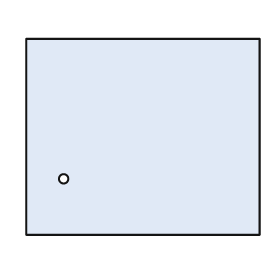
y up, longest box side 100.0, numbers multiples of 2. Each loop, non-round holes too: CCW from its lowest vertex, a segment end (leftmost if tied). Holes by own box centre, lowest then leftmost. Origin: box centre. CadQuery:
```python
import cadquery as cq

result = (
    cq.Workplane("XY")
    .moveTo(-50.0, -42.0)
    .lineTo(50.0, -42.0)
    .lineTo(50.0, 42.0)
    .lineTo(-50.0, 42.0)
    .close()
    .moveTo(-34.0, -18.0)
    .circle(2.0)
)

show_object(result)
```